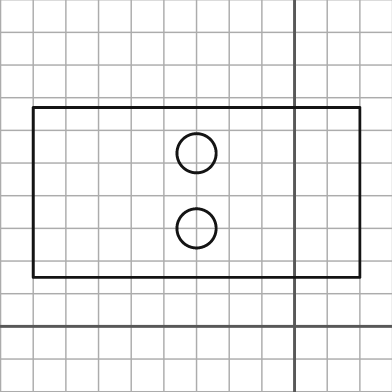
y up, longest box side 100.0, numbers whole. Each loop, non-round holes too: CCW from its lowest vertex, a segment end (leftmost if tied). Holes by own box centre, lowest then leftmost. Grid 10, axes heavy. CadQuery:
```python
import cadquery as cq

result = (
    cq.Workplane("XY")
    .moveTo(-80.0, 15.0)
    .lineTo(20.0, 15.0)
    .lineTo(20.0, 67.0)
    .lineTo(-80.0, 67.0)
    .close()
    .moveTo(-30.0, 30.0)
    .circle(6.0)
    .moveTo(-30.0, 53.0)
    .circle(6.0)
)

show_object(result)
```